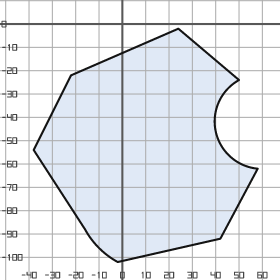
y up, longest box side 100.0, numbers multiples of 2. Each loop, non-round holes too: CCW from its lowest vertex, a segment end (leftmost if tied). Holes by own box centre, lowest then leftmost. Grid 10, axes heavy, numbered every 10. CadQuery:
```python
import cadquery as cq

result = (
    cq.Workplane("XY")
    .moveTo(-2.0, -102.0)
    .lineTo(42.0, -92.0)
    .lineTo(58.0, -62.0)
    .threePointArc((40.0, -46.0), (50.0, -24.0))
    .lineTo(24.0, -2.0)
    .lineTo(-22.0, -22.0)
    .lineTo(-38.0, -54.0)
    .lineTo(-16.0, -88.0)
    .threePointArc((-10.0, -96.0), (-2.0, -102.0))
    .close()
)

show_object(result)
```